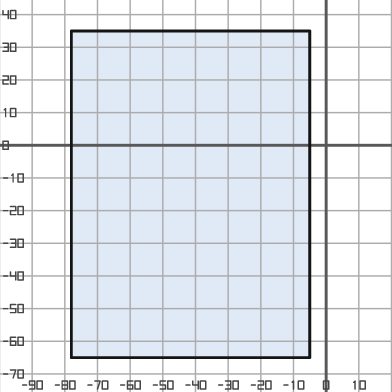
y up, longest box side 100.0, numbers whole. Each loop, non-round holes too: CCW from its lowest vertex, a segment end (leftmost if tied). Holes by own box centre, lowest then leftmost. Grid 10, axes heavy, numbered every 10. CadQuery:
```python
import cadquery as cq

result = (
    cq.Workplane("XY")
    .moveTo(-78.0, -65.0)
    .lineTo(-5.0, -65.0)
    .lineTo(-5.0, 35.0)
    .lineTo(-78.0, 35.0)
    .close()
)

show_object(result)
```